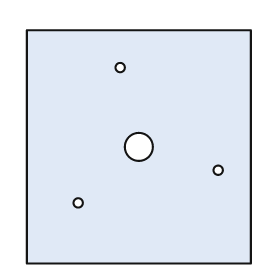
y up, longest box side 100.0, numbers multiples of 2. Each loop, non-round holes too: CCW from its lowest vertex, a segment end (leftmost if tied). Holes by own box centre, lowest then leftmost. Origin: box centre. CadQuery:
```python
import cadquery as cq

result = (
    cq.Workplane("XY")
    .moveTo(-48.0, -50.0)
    .lineTo(48.0, -50.0)
    .lineTo(48.0, 50.0)
    .lineTo(-48.0, 50.0)
    .close()
    .moveTo(-26.0, -24.0)
    .circle(2.0)
    .moveTo(34.0, -10.0)
    .circle(2.0)
    .moveTo(0.0, 0.0)
    .circle(6.0)
    .moveTo(-8.0, 34.0)
    .circle(2.0)
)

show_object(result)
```